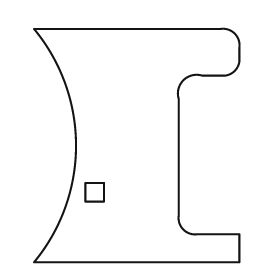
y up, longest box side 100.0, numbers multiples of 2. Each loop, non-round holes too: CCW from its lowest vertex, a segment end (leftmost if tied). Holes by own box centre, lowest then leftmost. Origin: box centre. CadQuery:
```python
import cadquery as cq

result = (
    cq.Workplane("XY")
    .moveTo(-44.0, -50.0)
    .lineTo(44.0, -50.0)
    .lineTo(44.0, -38.0)
    .lineTo(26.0, -38.0)
    .threePointArc((20.0, -36.0), (18.0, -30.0))
    .lineTo(18.0, 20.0)
    .threePointArc((20.0, 28.0), (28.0, 30.0))
    .lineTo(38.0, 30.0)
    .threePointArc((42.0, 32.0), (44.0, 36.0))
    .lineTo(44.0, 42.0)
    .threePointArc((42.0, 48.0), (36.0, 50.0))
    .lineTo(-44.0, 50.0)
    .threePointArc((-26.0, 0.0), (-44.0, -50.0))
    .close()
    .moveTo(-22.0, -24.0)
    .lineTo(-14.0, -24.0)
    .lineTo(-14.0, -16.0)
    .lineTo(-22.0, -16.0)
    .close()
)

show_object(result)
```